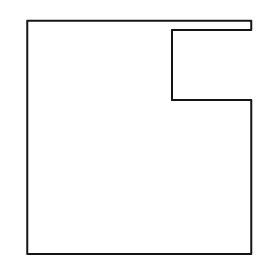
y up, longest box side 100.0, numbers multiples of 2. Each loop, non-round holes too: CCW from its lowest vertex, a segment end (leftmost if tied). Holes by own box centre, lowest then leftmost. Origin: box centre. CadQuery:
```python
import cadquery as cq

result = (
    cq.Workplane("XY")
    .moveTo(-48.0, -50.0)
    .lineTo(48.0, -50.0)
    .lineTo(48.0, 16.0)
    .lineTo(14.0, 16.0)
    .lineTo(14.0, 46.0)
    .lineTo(48.0, 46.0)
    .lineTo(48.0, 50.0)
    .lineTo(-48.0, 50.0)
    .close()
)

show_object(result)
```